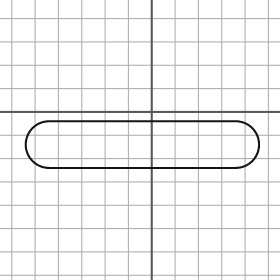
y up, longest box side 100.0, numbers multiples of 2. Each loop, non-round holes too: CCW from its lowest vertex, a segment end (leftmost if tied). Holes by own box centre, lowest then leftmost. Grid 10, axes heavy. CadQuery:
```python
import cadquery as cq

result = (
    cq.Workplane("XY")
    .moveTo(-44.0, -24.0)
    .lineTo(36.0, -24.0)
    .threePointArc((46.0, -14.0), (36.0, -4.0))
    .lineTo(-44.0, -4.0)
    .threePointArc((-54.0, -14.0), (-44.0, -24.0))
    .close()
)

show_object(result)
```